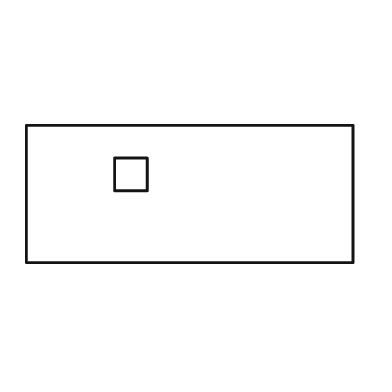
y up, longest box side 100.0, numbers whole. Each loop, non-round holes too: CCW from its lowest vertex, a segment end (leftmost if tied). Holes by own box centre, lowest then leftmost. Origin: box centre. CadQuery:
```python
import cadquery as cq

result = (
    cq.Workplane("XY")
    .moveTo(-50.0, -21.0)
    .lineTo(50.0, -21.0)
    .lineTo(50.0, 21.0)
    .lineTo(-50.0, 21.0)
    .close()
    .moveTo(-23.0, 1.0)
    .lineTo(-13.0, 1.0)
    .lineTo(-13.0, 11.0)
    .lineTo(-23.0, 11.0)
    .close()
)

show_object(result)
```